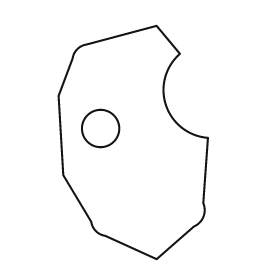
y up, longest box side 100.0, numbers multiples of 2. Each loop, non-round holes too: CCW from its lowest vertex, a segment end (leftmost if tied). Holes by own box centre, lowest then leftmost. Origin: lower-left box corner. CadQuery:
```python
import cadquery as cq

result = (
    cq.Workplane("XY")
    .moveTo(42.0, 0.0)
    .lineTo(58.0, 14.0)
    .threePointArc((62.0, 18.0), (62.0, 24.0))
    .lineTo(64.0, 52.0)
    .threePointArc((46.0, 66.0), (52.0, 88.0))
    .lineTo(42.0, 100.0)
    .lineTo(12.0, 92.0)
    .threePointArc((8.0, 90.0), (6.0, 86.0))
    .lineTo(0.0, 70.0)
    .lineTo(2.0, 36.0)
    .lineTo(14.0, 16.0)
    .threePointArc((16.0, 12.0), (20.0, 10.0))
    .close()
    .moveTo(18.0, 56.0)
    .circle(8.0)
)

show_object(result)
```